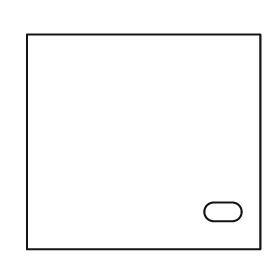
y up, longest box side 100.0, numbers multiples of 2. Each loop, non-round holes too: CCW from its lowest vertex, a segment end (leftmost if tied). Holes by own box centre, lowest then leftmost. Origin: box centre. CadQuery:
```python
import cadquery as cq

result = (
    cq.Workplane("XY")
    .moveTo(-50.0, -46.0)
    .lineTo(50.0, -46.0)
    .lineTo(50.0, 46.0)
    .lineTo(-50.0, 46.0)
    .close()
    .moveTo(30.0, -34.0)
    .lineTo(38.0, -34.0)
    .threePointArc((42.0, -30.0), (38.0, -26.0))
    .lineTo(30.0, -26.0)
    .threePointArc((26.0, -30.0), (30.0, -34.0))
    .close()
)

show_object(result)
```